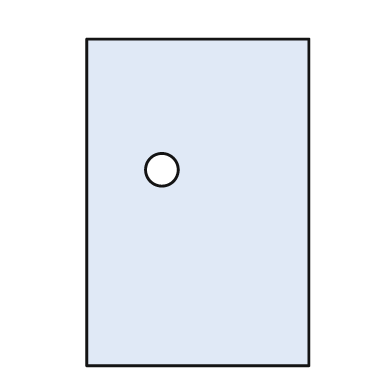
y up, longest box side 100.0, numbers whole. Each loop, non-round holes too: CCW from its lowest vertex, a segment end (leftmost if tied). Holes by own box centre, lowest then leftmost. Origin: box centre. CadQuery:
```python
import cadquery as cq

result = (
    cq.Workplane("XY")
    .moveTo(-34.0, -50.0)
    .lineTo(34.0, -50.0)
    .lineTo(34.0, 50.0)
    .lineTo(-34.0, 50.0)
    .close()
    .moveTo(-11.0, 10.0)
    .circle(5.0)
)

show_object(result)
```